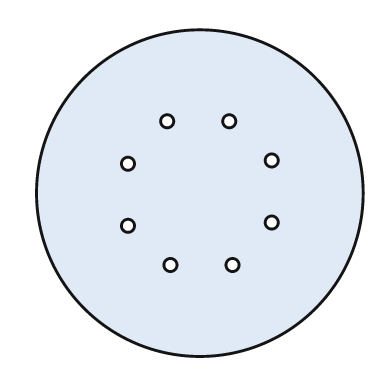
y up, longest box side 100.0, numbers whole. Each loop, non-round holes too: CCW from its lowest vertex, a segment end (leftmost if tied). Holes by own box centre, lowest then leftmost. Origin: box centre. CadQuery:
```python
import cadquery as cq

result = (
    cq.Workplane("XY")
    .moveTo(0.0, 0.0)
    .circle(50.0)
    .moveTo(-9.0, -22.0)
    .circle(2.0)
    .moveTo(10.0, -22.0)
    .circle(2.0)
    .moveTo(-22.0, -10.0)
    .circle(2.0)
    .moveTo(22.0, -9.0)
    .circle(2.0)
    .moveTo(-22.0, 9.0)
    .circle(2.0)
    .moveTo(22.0, 10.0)
    .circle(2.0)
    .moveTo(-10.0, 22.0)
    .circle(2.0)
    .moveTo(9.0, 22.0)
    .circle(2.0)
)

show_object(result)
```